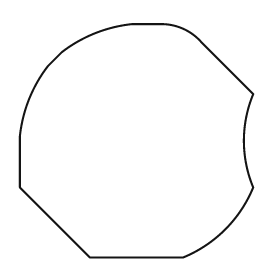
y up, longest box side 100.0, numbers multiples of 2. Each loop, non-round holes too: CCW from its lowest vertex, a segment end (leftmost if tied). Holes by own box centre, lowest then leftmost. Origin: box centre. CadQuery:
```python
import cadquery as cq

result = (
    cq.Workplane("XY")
    .moveTo(-20.0, -50.0)
    .lineTo(20.0, -50.0)
    .threePointArc((38.0, -38.0), (50.0, -20.0))
    .threePointArc((46.0, 0.0), (50.0, 20.0))
    .lineTo(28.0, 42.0)
    .threePointArc((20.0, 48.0), (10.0, 50.0))
    .lineTo(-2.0, 50.0)
    .threePointArc((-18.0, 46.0), (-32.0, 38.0))
    .lineTo(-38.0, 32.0)
    .threePointArc((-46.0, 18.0), (-50.0, 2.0))
    .lineTo(-50.0, -20.0)
    .close()
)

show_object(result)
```